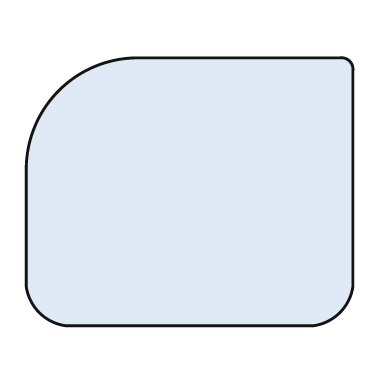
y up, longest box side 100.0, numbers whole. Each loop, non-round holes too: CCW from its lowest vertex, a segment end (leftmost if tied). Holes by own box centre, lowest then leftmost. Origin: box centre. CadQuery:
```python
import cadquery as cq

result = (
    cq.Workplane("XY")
    .moveTo(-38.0, -41.0)
    .lineTo(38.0, -41.0)
    .threePointArc((46.0, -37.0), (50.0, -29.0))
    .lineTo(50.0, 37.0)
    .threePointArc((49.0, 40.0), (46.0, 41.0))
    .lineTo(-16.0, 41.0)
    .threePointArc((-40.0, 31.0), (-50.0, 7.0))
    .lineTo(-50.0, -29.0)
    .threePointArc((-46.0, -37.0), (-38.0, -41.0))
    .close()
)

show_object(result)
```